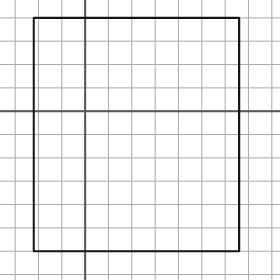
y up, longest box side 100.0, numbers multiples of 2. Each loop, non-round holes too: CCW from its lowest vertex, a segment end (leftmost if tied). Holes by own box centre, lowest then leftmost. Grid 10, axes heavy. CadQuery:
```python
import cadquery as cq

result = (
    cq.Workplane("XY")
    .moveTo(-22.0, -60.0)
    .lineTo(66.0, -60.0)
    .lineTo(66.0, 40.0)
    .lineTo(-22.0, 40.0)
    .close()
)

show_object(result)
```